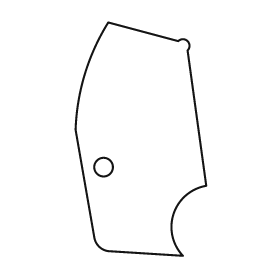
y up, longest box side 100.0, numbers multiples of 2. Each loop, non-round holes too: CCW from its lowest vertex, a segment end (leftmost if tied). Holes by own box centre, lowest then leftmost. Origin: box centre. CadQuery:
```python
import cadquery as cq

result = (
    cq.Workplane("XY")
    .moveTo(18.0, -50.0)
    .threePointArc((14.0, -32.0), (28.0, -20.0))
    .lineTo(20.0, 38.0)
    .threePointArc((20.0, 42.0), (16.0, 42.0))
    .lineTo(-14.0, 50.0)
    .threePointArc((-24.0, 28.0), (-28.0, 4.0))
    .lineTo(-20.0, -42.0)
    .threePointArc((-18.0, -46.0), (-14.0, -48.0))
    .close()
    .moveTo(-16.0, -12.0)
    .circle(4.0)
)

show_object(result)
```